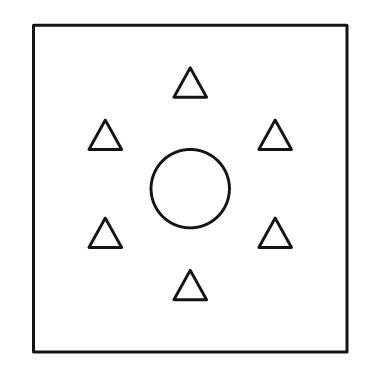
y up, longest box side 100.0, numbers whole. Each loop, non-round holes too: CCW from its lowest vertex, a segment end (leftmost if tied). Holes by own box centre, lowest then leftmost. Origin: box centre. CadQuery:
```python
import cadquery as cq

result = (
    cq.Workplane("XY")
    .moveTo(-48.0, -50.0)
    .lineTo(48.0, -50.0)
    .lineTo(48.0, 50.0)
    .lineTo(-48.0, 50.0)
    .close()
    .moveTo(-5.0, -34.0)
    .lineTo(5.0, -34.0)
    .lineTo(0.0, -25.0)
    .close()
    .moveTo(-31.0, -18.0)
    .lineTo(-21.0, -18.0)
    .lineTo(-26.0, -9.0)
    .close()
    .moveTo(21.0, -18.0)
    .lineTo(31.0, -18.0)
    .lineTo(26.0, -9.0)
    .close()
    .moveTo(0.0, 0.0)
    .circle(12.0)
    .moveTo(-31.0, 12.0)
    .lineTo(-21.0, 12.0)
    .lineTo(-26.0, 21.0)
    .close()
    .moveTo(21.0, 12.0)
    .lineTo(31.0, 12.0)
    .lineTo(26.0, 21.0)
    .close()
    .moveTo(-5.0, 28.0)
    .lineTo(5.0, 28.0)
    .lineTo(0.0, 37.0)
    .close()
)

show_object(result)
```